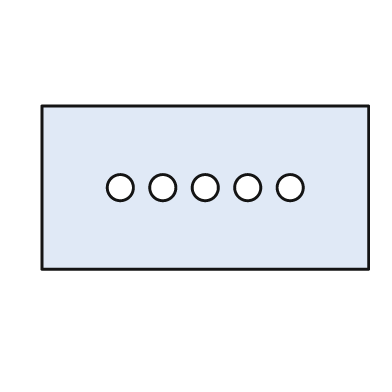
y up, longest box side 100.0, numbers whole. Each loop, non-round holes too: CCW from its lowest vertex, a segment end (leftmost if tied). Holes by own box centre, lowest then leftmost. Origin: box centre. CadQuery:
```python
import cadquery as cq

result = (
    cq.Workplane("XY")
    .moveTo(-50.0, -25.0)
    .lineTo(50.0, -25.0)
    .lineTo(50.0, 25.0)
    .lineTo(-50.0, 25.0)
    .close()
    .moveTo(-26.0, 0.0)
    .circle(4.0)
    .moveTo(-13.0, 0.0)
    .circle(4.0)
    .moveTo(0.0, 0.0)
    .circle(4.0)
    .moveTo(13.0, 0.0)
    .circle(4.0)
    .moveTo(26.0, 0.0)
    .circle(4.0)
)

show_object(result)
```